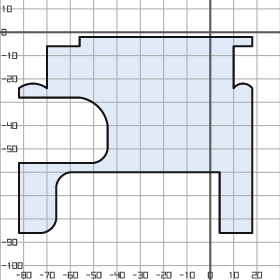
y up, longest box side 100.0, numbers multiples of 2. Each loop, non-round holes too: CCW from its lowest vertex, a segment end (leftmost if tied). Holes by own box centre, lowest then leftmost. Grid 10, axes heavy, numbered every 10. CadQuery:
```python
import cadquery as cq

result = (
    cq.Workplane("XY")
    .moveTo(-82.0, -86.0)
    .lineTo(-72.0, -86.0)
    .threePointArc((-68.0, -84.0), (-66.0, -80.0))
    .lineTo(-66.0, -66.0)
    .threePointArc((-64.0, -62.0), (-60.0, -60.0))
    .lineTo(4.0, -60.0)
    .lineTo(4.0, -86.0)
    .lineTo(18.0, -86.0)
    .lineTo(18.0, -24.0)
    .threePointArc((14.0, -22.0), (10.0, -24.0))
    .lineTo(10.0, -6.0)
    .lineTo(18.0, -6.0)
    .lineTo(18.0, -2.0)
    .lineTo(-56.0, -2.0)
    .lineTo(-56.0, -6.0)
    .lineTo(-70.0, -6.0)
    .lineTo(-70.0, -24.0)
    .threePointArc((-76.0, -22.0), (-82.0, -24.0))
    .lineTo(-82.0, -28.0)
    .lineTo(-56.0, -28.0)
    .threePointArc((-48.0, -32.0), (-44.0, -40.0))
    .lineTo(-44.0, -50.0)
    .threePointArc((-46.0, -54.0), (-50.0, -56.0))
    .lineTo(-82.0, -56.0)
    .close()
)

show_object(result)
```